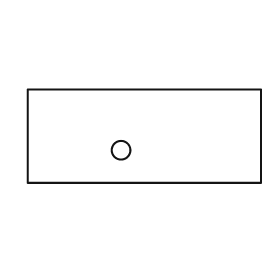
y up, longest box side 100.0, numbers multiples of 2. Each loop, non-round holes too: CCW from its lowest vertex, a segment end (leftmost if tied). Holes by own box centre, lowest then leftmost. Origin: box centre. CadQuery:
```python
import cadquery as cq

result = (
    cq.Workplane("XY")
    .moveTo(-50.0, -20.0)
    .lineTo(50.0, -20.0)
    .lineTo(50.0, 20.0)
    .lineTo(-50.0, 20.0)
    .close()
    .moveTo(-10.0, -6.0)
    .circle(4.0)
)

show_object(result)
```